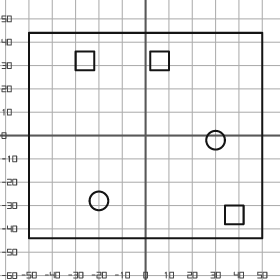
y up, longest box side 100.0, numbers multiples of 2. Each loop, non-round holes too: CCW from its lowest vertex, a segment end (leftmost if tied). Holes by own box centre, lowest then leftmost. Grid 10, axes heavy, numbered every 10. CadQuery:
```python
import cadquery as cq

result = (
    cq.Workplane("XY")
    .moveTo(-50.0, -44.0)
    .lineTo(50.0, -44.0)
    .lineTo(50.0, 44.0)
    .lineTo(-50.0, 44.0)
    .close()
    .moveTo(34.0, -38.0)
    .lineTo(42.0, -38.0)
    .lineTo(42.0, -30.0)
    .lineTo(34.0, -30.0)
    .close()
    .moveTo(-20.0, -28.0)
    .circle(4.0)
    .moveTo(30.0, -2.0)
    .circle(4.0)
    .moveTo(-30.0, 28.0)
    .lineTo(-22.0, 28.0)
    .lineTo(-22.0, 36.0)
    .lineTo(-30.0, 36.0)
    .close()
    .moveTo(2.0, 28.0)
    .lineTo(10.0, 28.0)
    .lineTo(10.0, 36.0)
    .lineTo(2.0, 36.0)
    .close()
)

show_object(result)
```